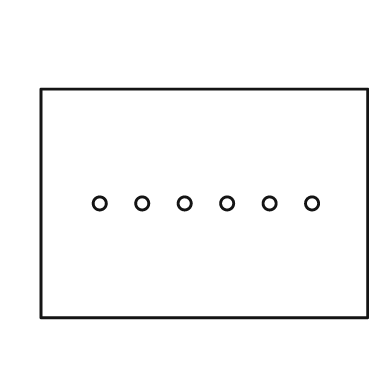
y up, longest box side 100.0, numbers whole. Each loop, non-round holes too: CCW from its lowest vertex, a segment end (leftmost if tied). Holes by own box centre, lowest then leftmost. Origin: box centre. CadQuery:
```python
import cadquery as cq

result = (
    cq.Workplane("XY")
    .moveTo(-50.0, -35.0)
    .lineTo(50.0, -35.0)
    .lineTo(50.0, 35.0)
    .lineTo(-50.0, 35.0)
    .close()
    .moveTo(-32.0, 0.0)
    .circle(2.0)
    .moveTo(-19.0, 0.0)
    .circle(2.0)
    .moveTo(-6.0, 0.0)
    .circle(2.0)
    .moveTo(7.0, 0.0)
    .circle(2.0)
    .moveTo(20.0, 0.0)
    .circle(2.0)
    .moveTo(33.0, 0.0)
    .circle(2.0)
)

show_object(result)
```